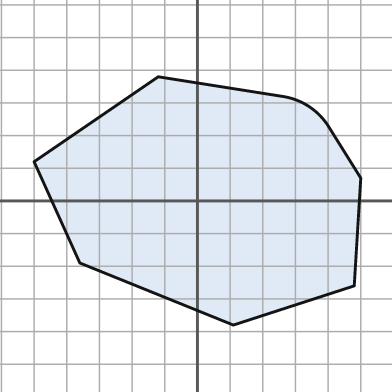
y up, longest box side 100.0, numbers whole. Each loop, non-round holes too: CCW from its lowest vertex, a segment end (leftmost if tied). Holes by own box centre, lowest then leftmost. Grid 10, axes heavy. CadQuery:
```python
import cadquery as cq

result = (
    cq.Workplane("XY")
    .moveTo(11.0, -38.0)
    .lineTo(48.0, -26.0)
    .lineTo(50.0, 7.0)
    .lineTo(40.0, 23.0)
    .threePointArc((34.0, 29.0), (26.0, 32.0))
    .lineTo(-12.0, 38.0)
    .lineTo(-50.0, 12.0)
    .lineTo(-36.0, -19.0)
    .close()
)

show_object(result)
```